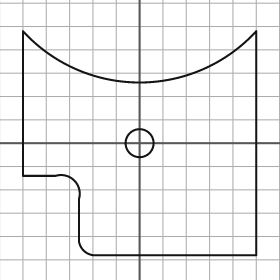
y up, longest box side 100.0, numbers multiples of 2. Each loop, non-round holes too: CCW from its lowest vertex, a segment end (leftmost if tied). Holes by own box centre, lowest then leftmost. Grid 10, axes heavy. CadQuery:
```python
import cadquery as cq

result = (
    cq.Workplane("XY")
    .moveTo(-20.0, -48.0)
    .lineTo(50.0, -48.0)
    .lineTo(50.0, 48.0)
    .threePointArc((0.0, 26.0), (-50.0, 48.0))
    .lineTo(-50.0, -14.0)
    .lineTo(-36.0, -14.0)
    .threePointArc((-28.0, -16.0), (-26.0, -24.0))
    .lineTo(-26.0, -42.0)
    .threePointArc((-24.0, -46.0), (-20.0, -48.0))
    .close()
    .moveTo(0.0, 0.0)
    .circle(6.0)
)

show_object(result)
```